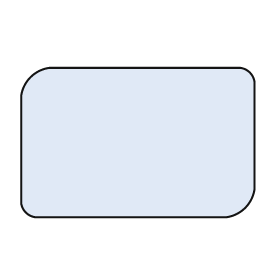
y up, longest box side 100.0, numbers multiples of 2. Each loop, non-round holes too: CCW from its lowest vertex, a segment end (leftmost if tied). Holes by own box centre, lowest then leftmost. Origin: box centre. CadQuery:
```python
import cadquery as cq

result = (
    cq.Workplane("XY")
    .moveTo(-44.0, -32.0)
    .lineTo(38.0, -32.0)
    .threePointArc((46.0, -28.0), (50.0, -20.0))
    .lineTo(50.0, 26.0)
    .threePointArc((48.0, 30.0), (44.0, 32.0))
    .lineTo(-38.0, 32.0)
    .threePointArc((-46.0, 28.0), (-50.0, 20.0))
    .lineTo(-50.0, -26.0)
    .threePointArc((-48.0, -30.0), (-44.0, -32.0))
    .close()
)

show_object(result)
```